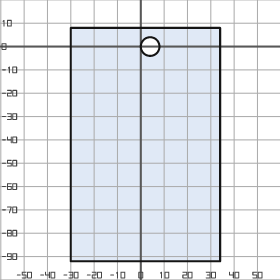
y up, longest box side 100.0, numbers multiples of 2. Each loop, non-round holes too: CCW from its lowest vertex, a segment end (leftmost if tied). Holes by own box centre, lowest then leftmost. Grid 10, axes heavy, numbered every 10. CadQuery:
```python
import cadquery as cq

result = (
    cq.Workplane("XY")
    .moveTo(-30.0, -92.0)
    .lineTo(34.0, -92.0)
    .lineTo(34.0, 8.0)
    .lineTo(-30.0, 8.0)
    .close()
    .moveTo(4.0, 0.0)
    .circle(4.0)
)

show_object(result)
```